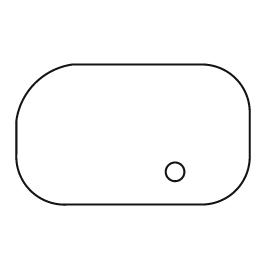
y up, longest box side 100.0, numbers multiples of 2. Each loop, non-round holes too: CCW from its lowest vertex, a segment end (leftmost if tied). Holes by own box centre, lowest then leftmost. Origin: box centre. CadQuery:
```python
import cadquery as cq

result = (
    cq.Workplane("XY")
    .moveTo(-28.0, -30.0)
    .lineTo(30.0, -30.0)
    .threePointArc((44.0, -24.0), (50.0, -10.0))
    .lineTo(50.0, 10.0)
    .threePointArc((44.0, 24.0), (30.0, 30.0))
    .lineTo(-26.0, 30.0)
    .threePointArc((-42.0, 22.0), (-50.0, 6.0))
    .lineTo(-50.0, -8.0)
    .threePointArc((-44.0, -24.0), (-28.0, -30.0))
    .close()
    .moveTo(18.0, -16.0)
    .circle(4.0)
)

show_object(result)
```